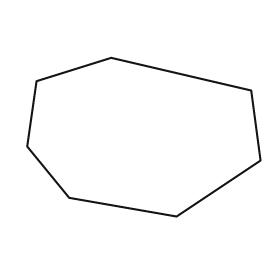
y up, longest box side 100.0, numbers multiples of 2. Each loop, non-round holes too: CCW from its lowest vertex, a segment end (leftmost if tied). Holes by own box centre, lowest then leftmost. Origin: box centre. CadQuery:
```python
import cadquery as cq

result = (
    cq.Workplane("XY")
    .moveTo(14.0, -34.0)
    .lineTo(50.0, -10.0)
    .lineTo(46.0, 20.0)
    .lineTo(-14.0, 34.0)
    .lineTo(-46.0, 24.0)
    .lineTo(-50.0, -4.0)
    .lineTo(-32.0, -26.0)
    .close()
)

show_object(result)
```